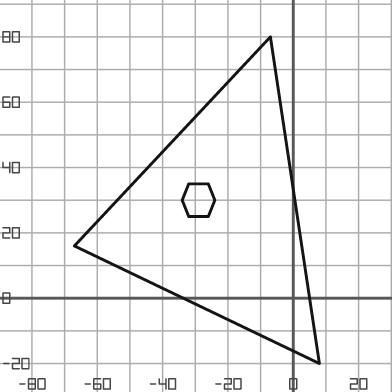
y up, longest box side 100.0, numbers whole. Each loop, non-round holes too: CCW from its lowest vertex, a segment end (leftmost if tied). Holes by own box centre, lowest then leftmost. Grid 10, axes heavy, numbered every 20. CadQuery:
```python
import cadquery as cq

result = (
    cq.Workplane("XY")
    .moveTo(8.0, -20.0)
    .lineTo(-7.0, 80.0)
    .lineTo(-67.0, 16.0)
    .close()
    .moveTo(-32.0, 25.0)
    .lineTo(-26.0, 25.0)
    .lineTo(-24.0, 30.0)
    .lineTo(-26.0, 35.0)
    .lineTo(-32.0, 35.0)
    .lineTo(-34.0, 30.0)
    .close()
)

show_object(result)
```